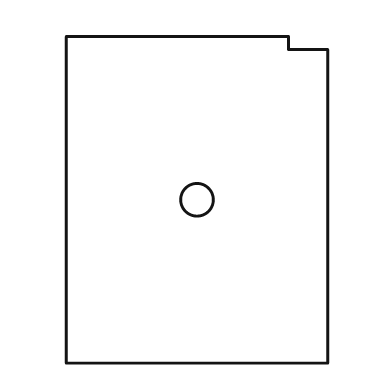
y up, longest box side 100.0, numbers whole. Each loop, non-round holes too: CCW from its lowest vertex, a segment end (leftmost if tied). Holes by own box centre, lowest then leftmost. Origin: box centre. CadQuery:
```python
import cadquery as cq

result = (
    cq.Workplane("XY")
    .moveTo(-40.0, -50.0)
    .lineTo(40.0, -50.0)
    .lineTo(40.0, 46.0)
    .lineTo(28.0, 46.0)
    .lineTo(28.0, 50.0)
    .lineTo(-40.0, 50.0)
    .close()
    .moveTo(0.0, 0.0)
    .circle(5.0)
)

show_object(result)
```